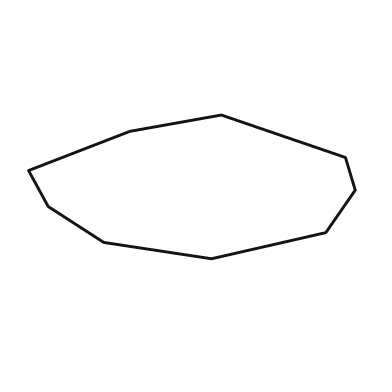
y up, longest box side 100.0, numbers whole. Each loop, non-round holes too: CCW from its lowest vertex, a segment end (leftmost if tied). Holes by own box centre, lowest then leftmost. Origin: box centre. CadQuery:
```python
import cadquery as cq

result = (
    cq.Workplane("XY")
    .moveTo(6.0, -22.0)
    .lineTo(41.0, -14.0)
    .lineTo(50.0, -1.0)
    .lineTo(47.0, 9.0)
    .lineTo(9.0, 22.0)
    .lineTo(-19.0, 17.0)
    .lineTo(-50.0, 5.0)
    .lineTo(-44.0, -6.0)
    .lineTo(-27.0, -17.0)
    .close()
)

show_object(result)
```